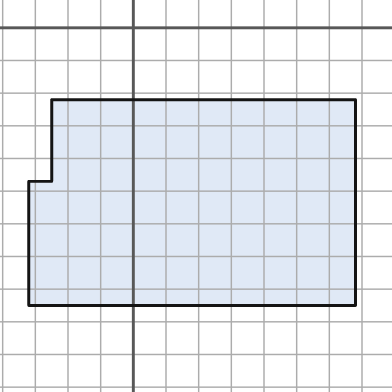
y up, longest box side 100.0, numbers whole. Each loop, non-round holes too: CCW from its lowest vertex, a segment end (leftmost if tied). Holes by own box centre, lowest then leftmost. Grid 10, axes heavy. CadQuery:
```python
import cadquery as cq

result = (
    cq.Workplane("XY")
    .moveTo(-32.0, -85.0)
    .lineTo(68.0, -85.0)
    .lineTo(68.0, -22.0)
    .lineTo(-25.0, -22.0)
    .lineTo(-25.0, -47.0)
    .lineTo(-32.0, -47.0)
    .close()
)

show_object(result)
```